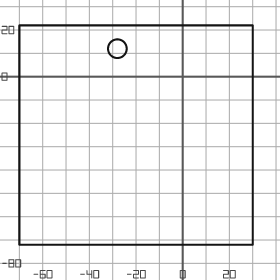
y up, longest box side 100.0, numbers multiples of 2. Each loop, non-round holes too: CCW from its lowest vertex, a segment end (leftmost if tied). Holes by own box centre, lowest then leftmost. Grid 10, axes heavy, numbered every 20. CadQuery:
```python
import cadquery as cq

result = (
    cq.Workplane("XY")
    .moveTo(-70.0, -72.0)
    .lineTo(30.0, -72.0)
    .lineTo(30.0, 22.0)
    .lineTo(-70.0, 22.0)
    .close()
    .moveTo(-28.0, 12.0)
    .circle(4.0)
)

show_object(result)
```